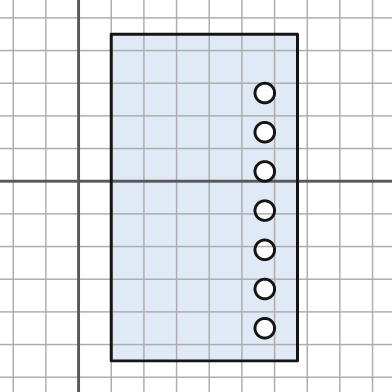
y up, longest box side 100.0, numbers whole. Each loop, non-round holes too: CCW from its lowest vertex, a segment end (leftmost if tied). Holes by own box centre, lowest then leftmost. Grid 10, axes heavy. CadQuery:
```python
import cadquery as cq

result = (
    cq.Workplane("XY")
    .moveTo(10.0, -55.0)
    .lineTo(67.0, -55.0)
    .lineTo(67.0, 45.0)
    .lineTo(10.0, 45.0)
    .close()
    .moveTo(57.0, -45.0)
    .circle(3.0)
    .moveTo(57.0, -33.0)
    .circle(3.0)
    .moveTo(57.0, -21.0)
    .circle(3.0)
    .moveTo(57.0, -9.0)
    .circle(3.0)
    .moveTo(57.0, 3.0)
    .circle(3.0)
    .moveTo(57.0, 15.0)
    .circle(3.0)
    .moveTo(57.0, 27.0)
    .circle(3.0)
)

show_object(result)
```